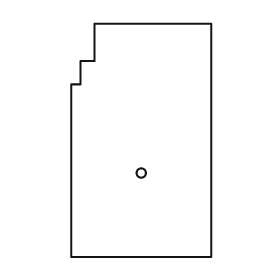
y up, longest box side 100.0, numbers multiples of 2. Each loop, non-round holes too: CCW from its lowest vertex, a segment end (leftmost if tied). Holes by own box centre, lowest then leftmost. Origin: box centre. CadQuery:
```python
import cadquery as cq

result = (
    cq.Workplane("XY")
    .moveTo(-30.0, -50.0)
    .lineTo(30.0, -50.0)
    .lineTo(30.0, 50.0)
    .lineTo(-20.0, 50.0)
    .lineTo(-20.0, 34.0)
    .lineTo(-26.0, 34.0)
    .lineTo(-26.0, 24.0)
    .lineTo(-30.0, 24.0)
    .close()
    .moveTo(0.0, -14.0)
    .circle(2.0)
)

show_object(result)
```